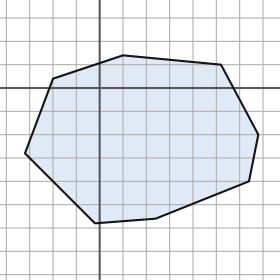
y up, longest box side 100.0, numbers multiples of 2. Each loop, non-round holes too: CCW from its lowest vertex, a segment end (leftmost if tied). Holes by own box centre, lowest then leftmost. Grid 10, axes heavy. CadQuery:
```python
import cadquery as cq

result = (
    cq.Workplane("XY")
    .moveTo(-2.0, -58.0)
    .lineTo(24.0, -56.0)
    .lineTo(64.0, -40.0)
    .lineTo(68.0, -20.0)
    .lineTo(52.0, 10.0)
    .lineTo(10.0, 14.0)
    .lineTo(-20.0, 4.0)
    .lineTo(-32.0, -28.0)
    .close()
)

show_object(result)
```